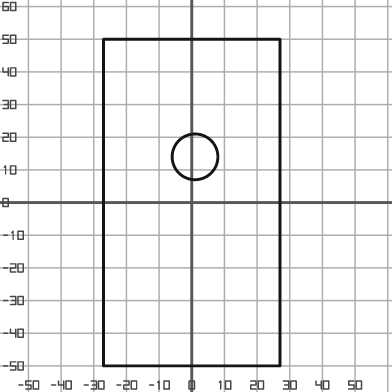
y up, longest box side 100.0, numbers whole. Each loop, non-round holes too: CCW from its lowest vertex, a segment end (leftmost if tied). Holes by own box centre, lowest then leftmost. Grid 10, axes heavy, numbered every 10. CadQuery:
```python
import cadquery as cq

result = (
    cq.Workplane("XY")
    .moveTo(-27.0, -50.0)
    .lineTo(27.0, -50.0)
    .lineTo(27.0, 50.0)
    .lineTo(-27.0, 50.0)
    .close()
    .moveTo(1.0, 14.0)
    .circle(7.0)
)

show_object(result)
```